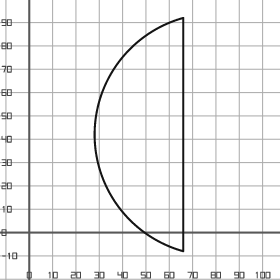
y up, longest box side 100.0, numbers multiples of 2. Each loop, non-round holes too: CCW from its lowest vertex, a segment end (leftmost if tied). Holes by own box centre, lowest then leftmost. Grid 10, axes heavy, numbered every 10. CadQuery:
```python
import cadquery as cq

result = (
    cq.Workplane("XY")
    .moveTo(66.0, -8.0)
    .lineTo(66.0, 92.0)
    .threePointArc((28.0, 42.0), (66.0, -8.0))
    .close()
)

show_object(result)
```